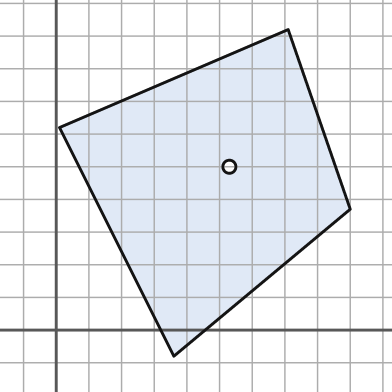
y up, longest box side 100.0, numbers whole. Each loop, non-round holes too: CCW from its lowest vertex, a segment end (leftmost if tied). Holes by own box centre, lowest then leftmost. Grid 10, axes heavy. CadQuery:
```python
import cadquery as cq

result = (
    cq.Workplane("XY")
    .moveTo(36.0, -8.0)
    .lineTo(90.0, 37.0)
    .lineTo(71.0, 92.0)
    .lineTo(1.0, 62.0)
    .close()
    .moveTo(53.0, 50.0)
    .circle(2.0)
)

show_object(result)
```